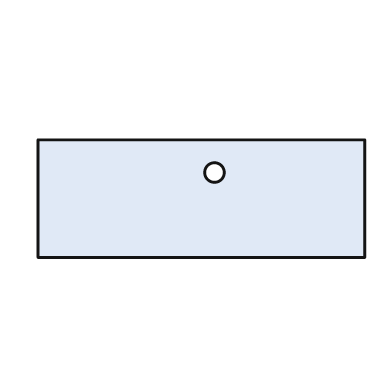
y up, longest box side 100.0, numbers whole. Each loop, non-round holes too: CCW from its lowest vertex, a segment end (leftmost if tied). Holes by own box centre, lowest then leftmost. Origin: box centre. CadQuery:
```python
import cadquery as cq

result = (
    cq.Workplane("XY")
    .moveTo(-50.0, -18.0)
    .lineTo(50.0, -18.0)
    .lineTo(50.0, 18.0)
    .lineTo(-50.0, 18.0)
    .close()
    .moveTo(4.0, 8.0)
    .circle(3.0)
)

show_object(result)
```